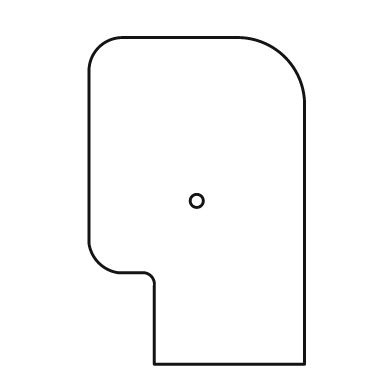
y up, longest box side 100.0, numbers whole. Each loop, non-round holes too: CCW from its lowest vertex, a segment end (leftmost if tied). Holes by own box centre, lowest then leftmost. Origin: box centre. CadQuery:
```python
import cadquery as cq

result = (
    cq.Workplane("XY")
    .moveTo(-13.0, -50.0)
    .lineTo(33.0, -50.0)
    .lineTo(33.0, 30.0)
    .threePointArc((27.0, 44.0), (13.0, 50.0))
    .lineTo(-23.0, 50.0)
    .threePointArc((-30.0, 47.0), (-33.0, 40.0))
    .lineTo(-33.0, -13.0)
    .threePointArc((-30.0, -19.0), (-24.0, -22.0))
    .lineTo(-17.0, -22.0)
    .threePointArc((-14.0, -23.0), (-13.0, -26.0))
    .close()
    .moveTo(0.0, 0.0)
    .circle(2.0)
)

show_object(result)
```